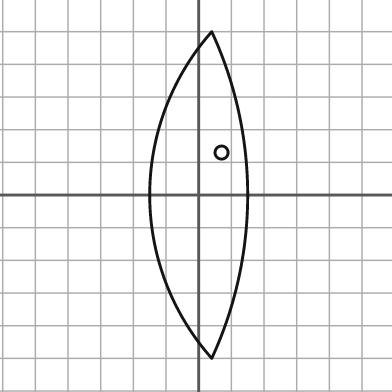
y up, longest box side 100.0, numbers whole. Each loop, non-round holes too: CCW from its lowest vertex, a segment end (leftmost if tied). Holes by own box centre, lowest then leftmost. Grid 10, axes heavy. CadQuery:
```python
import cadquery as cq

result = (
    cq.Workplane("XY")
    .moveTo(4.0, -50.0)
    .threePointArc((15.0, 0.0), (4.0, 50.0))
    .threePointArc((-15.0, 0.0), (4.0, -50.0))
    .close()
    .moveTo(7.0, 13.0)
    .circle(2.0)
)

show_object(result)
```